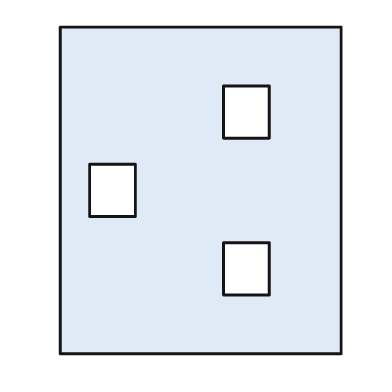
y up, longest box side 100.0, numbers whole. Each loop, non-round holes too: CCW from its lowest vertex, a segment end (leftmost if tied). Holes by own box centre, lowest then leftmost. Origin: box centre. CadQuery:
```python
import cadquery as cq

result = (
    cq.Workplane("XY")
    .moveTo(-43.0, -50.0)
    .lineTo(43.0, -50.0)
    .lineTo(43.0, 50.0)
    .lineTo(-43.0, 50.0)
    .close()
    .moveTo(7.0, -32.0)
    .lineTo(21.0, -32.0)
    .lineTo(21.0, -16.0)
    .lineTo(7.0, -16.0)
    .close()
    .moveTo(-34.0, -8.0)
    .lineTo(-20.0, -8.0)
    .lineTo(-20.0, 8.0)
    .lineTo(-34.0, 8.0)
    .close()
    .moveTo(7.0, 16.0)
    .lineTo(21.0, 16.0)
    .lineTo(21.0, 32.0)
    .lineTo(7.0, 32.0)
    .close()
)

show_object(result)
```